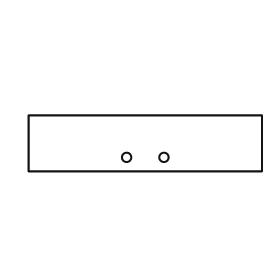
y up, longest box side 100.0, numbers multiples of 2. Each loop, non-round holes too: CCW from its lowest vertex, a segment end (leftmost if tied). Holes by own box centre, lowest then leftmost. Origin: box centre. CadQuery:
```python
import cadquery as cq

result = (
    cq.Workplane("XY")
    .moveTo(-50.0, -12.0)
    .lineTo(50.0, -12.0)
    .lineTo(50.0, 12.0)
    .lineTo(-50.0, 12.0)
    .close()
    .moveTo(-8.0, -6.0)
    .circle(2.0)
    .moveTo(8.0, -6.0)
    .circle(2.0)
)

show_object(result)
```